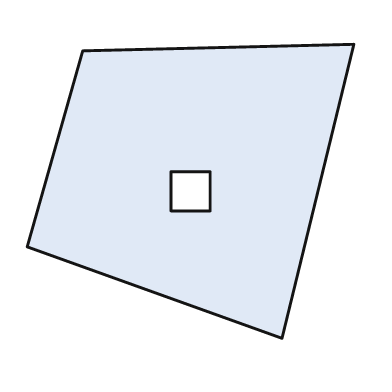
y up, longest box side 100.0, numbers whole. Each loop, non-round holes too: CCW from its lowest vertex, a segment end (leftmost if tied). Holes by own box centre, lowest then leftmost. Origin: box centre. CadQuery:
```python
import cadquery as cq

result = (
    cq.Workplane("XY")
    .moveTo(28.0, -45.0)
    .lineTo(50.0, 45.0)
    .lineTo(-33.0, 43.0)
    .lineTo(-50.0, -17.0)
    .close()
    .moveTo(-6.0, -6.0)
    .lineTo(6.0, -6.0)
    .lineTo(6.0, 6.0)
    .lineTo(-6.0, 6.0)
    .close()
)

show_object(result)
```